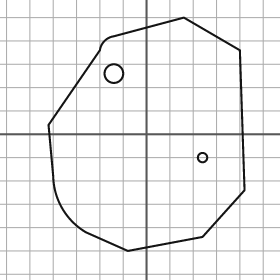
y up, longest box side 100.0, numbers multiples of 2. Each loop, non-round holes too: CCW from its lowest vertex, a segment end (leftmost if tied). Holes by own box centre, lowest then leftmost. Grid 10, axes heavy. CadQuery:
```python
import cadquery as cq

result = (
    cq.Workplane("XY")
    .moveTo(-8.0, -50.0)
    .lineTo(24.0, -44.0)
    .lineTo(42.0, -24.0)
    .lineTo(40.0, 36.0)
    .lineTo(16.0, 50.0)
    .lineTo(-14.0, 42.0)
    .threePointArc((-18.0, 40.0), (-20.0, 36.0))
    .lineTo(-42.0, 4.0)
    .lineTo(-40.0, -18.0)
    .threePointArc((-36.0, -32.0), (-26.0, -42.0))
    .close()
    .moveTo(24.0, -10.0)
    .circle(2.0)
    .moveTo(-14.0, 26.0)
    .circle(4.0)
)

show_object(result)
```